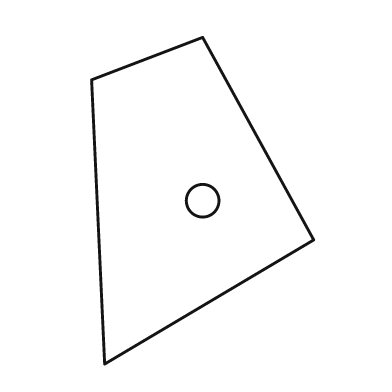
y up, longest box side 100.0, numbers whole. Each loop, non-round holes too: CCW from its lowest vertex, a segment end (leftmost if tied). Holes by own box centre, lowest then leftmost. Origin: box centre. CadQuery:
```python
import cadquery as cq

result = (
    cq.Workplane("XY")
    .moveTo(-30.0, -50.0)
    .lineTo(34.0, -12.0)
    .lineTo(0.0, 50.0)
    .lineTo(-34.0, 37.0)
    .close()
    .moveTo(0.0, 0.0)
    .circle(5.0)
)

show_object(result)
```